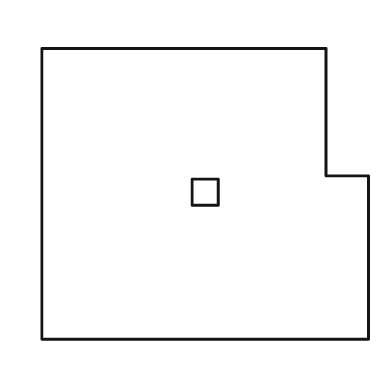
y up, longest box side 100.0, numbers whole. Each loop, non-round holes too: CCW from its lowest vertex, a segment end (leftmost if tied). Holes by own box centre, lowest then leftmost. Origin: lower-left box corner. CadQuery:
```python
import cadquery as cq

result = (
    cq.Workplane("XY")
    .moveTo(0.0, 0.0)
    .lineTo(100.0, 0.0)
    .lineTo(100.0, 50.0)
    .lineTo(87.0, 50.0)
    .lineTo(87.0, 89.0)
    .lineTo(0.0, 89.0)
    .close()
    .moveTo(46.0, 41.0)
    .lineTo(54.0, 41.0)
    .lineTo(54.0, 49.0)
    .lineTo(46.0, 49.0)
    .close()
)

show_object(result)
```